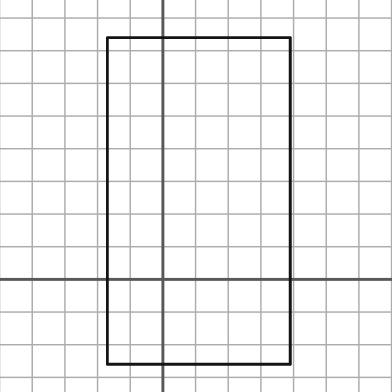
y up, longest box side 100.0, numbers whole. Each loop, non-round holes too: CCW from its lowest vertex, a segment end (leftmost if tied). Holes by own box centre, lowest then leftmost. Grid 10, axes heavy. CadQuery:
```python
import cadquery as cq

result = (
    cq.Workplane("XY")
    .moveTo(-17.0, -26.0)
    .lineTo(39.0, -26.0)
    .lineTo(39.0, 74.0)
    .lineTo(-17.0, 74.0)
    .close()
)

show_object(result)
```